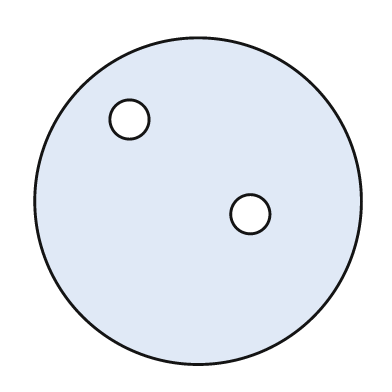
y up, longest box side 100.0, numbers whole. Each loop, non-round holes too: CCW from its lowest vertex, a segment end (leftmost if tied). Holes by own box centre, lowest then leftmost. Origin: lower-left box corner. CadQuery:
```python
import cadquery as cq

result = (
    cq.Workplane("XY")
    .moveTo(50.0, 50.0)
    .circle(50.0)
    .moveTo(66.0, 46.0)
    .circle(6.0)
    .moveTo(29.0, 75.0)
    .circle(6.0)
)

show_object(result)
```